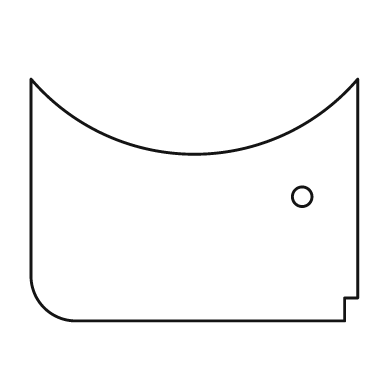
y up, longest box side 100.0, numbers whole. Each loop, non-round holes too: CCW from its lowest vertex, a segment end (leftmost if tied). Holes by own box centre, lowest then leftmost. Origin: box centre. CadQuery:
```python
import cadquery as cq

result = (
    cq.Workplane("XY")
    .moveTo(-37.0, -37.0)
    .lineTo(46.0, -37.0)
    .lineTo(46.0, -30.0)
    .lineTo(50.0, -30.0)
    .lineTo(50.0, 37.0)
    .threePointArc((0.0, 14.0), (-50.0, 37.0))
    .lineTo(-50.0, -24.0)
    .threePointArc((-46.0, -33.0), (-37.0, -37.0))
    .close()
    .moveTo(33.0, 1.0)
    .circle(3.0)
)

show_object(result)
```